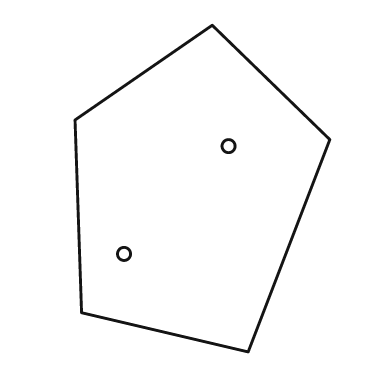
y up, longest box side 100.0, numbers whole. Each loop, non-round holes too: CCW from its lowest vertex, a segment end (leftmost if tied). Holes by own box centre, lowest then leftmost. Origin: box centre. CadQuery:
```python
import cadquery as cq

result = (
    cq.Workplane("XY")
    .moveTo(14.0, -50.0)
    .lineTo(39.0, 15.0)
    .lineTo(3.0, 50.0)
    .lineTo(-39.0, 21.0)
    .lineTo(-37.0, -38.0)
    .close()
    .moveTo(-24.0, -20.0)
    .circle(2.0)
    .moveTo(8.0, 13.0)
    .circle(2.0)
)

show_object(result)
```